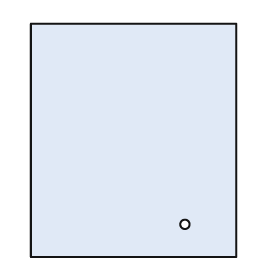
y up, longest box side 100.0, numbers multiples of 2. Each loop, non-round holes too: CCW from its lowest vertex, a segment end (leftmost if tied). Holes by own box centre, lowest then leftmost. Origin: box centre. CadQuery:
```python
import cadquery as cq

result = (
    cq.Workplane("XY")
    .moveTo(-44.0, -50.0)
    .lineTo(44.0, -50.0)
    .lineTo(44.0, 50.0)
    .lineTo(-44.0, 50.0)
    .close()
    .moveTo(22.0, -36.0)
    .circle(2.0)
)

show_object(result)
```